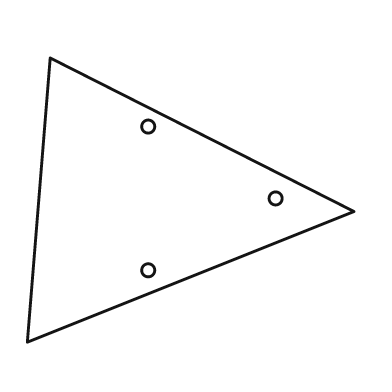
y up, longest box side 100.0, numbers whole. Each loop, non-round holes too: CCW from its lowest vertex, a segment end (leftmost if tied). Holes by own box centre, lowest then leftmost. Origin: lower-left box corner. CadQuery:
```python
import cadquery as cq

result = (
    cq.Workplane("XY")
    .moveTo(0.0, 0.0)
    .lineTo(100.0, 40.0)
    .lineTo(7.0, 87.0)
    .close()
    .moveTo(37.0, 22.0)
    .circle(2.0)
    .moveTo(76.0, 44.0)
    .circle(2.0)
    .moveTo(37.0, 66.0)
    .circle(2.0)
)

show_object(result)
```